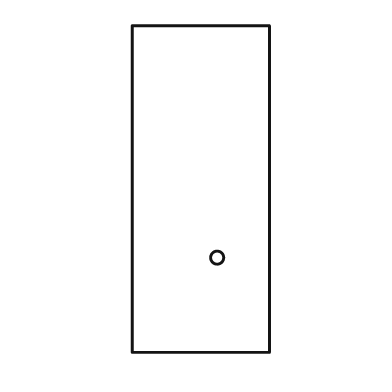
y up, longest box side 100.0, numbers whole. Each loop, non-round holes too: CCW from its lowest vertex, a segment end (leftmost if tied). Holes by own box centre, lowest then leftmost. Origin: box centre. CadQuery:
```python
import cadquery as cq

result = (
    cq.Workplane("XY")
    .moveTo(-21.0, -50.0)
    .lineTo(21.0, -50.0)
    .lineTo(21.0, 50.0)
    .lineTo(-21.0, 50.0)
    .close()
    .moveTo(5.0, -21.0)
    .circle(2.0)
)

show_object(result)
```